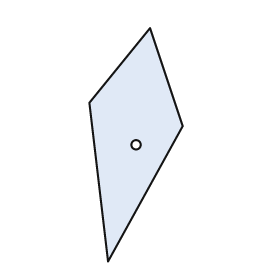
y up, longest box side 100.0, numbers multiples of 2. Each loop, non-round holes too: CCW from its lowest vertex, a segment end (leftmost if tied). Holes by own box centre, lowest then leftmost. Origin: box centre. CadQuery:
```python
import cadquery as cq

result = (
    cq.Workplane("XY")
    .moveTo(-12.0, -50.0)
    .lineTo(20.0, 8.0)
    .lineTo(6.0, 50.0)
    .lineTo(-20.0, 18.0)
    .close()
    .moveTo(0.0, 0.0)
    .circle(2.0)
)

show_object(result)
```